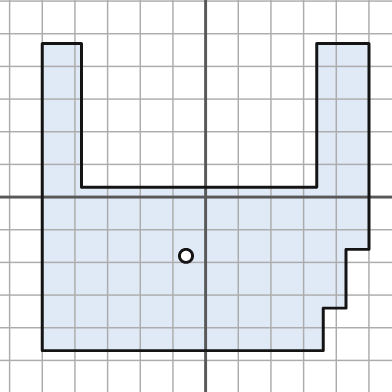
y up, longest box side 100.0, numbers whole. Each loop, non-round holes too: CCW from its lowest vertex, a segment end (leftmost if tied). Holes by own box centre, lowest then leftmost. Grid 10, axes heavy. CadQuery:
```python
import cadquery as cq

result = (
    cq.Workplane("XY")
    .moveTo(-50.0, -47.0)
    .lineTo(36.0, -47.0)
    .lineTo(36.0, -34.0)
    .lineTo(43.0, -34.0)
    .lineTo(43.0, -16.0)
    .lineTo(50.0, -16.0)
    .lineTo(50.0, 47.0)
    .lineTo(34.0, 47.0)
    .lineTo(34.0, 3.0)
    .lineTo(-38.0, 3.0)
    .lineTo(-38.0, 47.0)
    .lineTo(-50.0, 47.0)
    .close()
    .moveTo(-6.0, -18.0)
    .circle(2.0)
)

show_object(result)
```